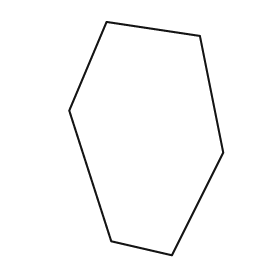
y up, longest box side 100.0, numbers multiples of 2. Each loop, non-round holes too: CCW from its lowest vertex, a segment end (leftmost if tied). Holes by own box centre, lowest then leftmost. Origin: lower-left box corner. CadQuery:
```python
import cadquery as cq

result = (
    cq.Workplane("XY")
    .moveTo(44.0, 0.0)
    .lineTo(66.0, 44.0)
    .lineTo(56.0, 94.0)
    .lineTo(16.0, 100.0)
    .lineTo(0.0, 62.0)
    .lineTo(18.0, 6.0)
    .close()
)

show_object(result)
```